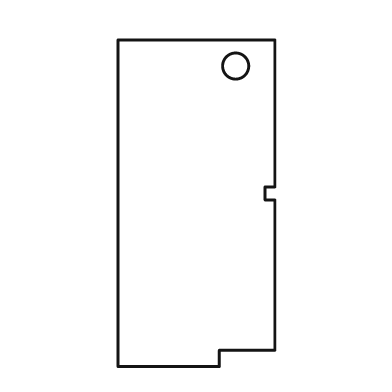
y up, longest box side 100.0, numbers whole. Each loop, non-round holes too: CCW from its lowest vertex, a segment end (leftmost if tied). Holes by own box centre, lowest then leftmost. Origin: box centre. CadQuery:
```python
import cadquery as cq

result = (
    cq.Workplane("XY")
    .moveTo(-24.0, -50.0)
    .lineTo(7.0, -50.0)
    .lineTo(7.0, -45.0)
    .lineTo(24.0, -45.0)
    .lineTo(24.0, 1.0)
    .lineTo(21.0, 1.0)
    .lineTo(21.0, 5.0)
    .lineTo(24.0, 5.0)
    .lineTo(24.0, 50.0)
    .lineTo(-24.0, 50.0)
    .close()
    .moveTo(12.0, 42.0)
    .circle(4.0)
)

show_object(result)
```